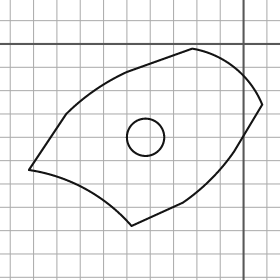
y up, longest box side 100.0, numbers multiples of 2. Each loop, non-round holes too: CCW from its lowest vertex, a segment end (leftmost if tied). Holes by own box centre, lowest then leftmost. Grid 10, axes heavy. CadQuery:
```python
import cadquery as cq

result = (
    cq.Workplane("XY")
    .moveTo(-48.0, -78.0)
    .lineTo(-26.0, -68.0)
    .threePointArc((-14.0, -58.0), (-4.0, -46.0))
    .lineTo(8.0, -26.0)
    .threePointArc((-4.0, -10.0), (-22.0, -2.0))
    .lineTo(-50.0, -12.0)
    .threePointArc((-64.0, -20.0), (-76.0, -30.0))
    .lineTo(-92.0, -54.0)
    .threePointArc((-68.0, -62.0), (-48.0, -78.0))
    .close()
    .moveTo(-42.0, -40.0)
    .circle(8.0)
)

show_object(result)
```